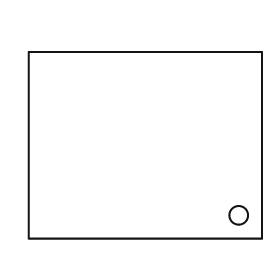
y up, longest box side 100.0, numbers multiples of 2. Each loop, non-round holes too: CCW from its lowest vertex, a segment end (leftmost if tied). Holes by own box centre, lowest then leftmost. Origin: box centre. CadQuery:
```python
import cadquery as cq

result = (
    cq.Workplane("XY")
    .moveTo(-50.0, -40.0)
    .lineTo(50.0, -40.0)
    .lineTo(50.0, 40.0)
    .lineTo(-50.0, 40.0)
    .close()
    .moveTo(40.0, -30.0)
    .circle(4.0)
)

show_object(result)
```